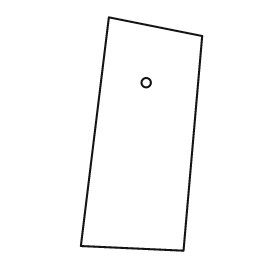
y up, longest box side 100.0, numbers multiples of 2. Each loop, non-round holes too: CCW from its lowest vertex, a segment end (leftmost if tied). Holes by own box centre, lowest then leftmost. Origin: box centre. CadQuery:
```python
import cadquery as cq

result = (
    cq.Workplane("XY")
    .moveTo(18.0, -50.0)
    .lineTo(26.0, 42.0)
    .lineTo(-14.0, 50.0)
    .lineTo(-26.0, -48.0)
    .close()
    .moveTo(2.0, 22.0)
    .circle(2.0)
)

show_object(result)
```